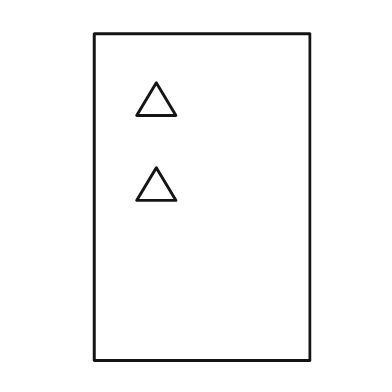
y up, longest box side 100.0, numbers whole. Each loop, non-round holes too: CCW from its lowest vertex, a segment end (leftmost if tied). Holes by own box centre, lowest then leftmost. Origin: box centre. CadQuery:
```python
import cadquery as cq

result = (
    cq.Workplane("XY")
    .moveTo(-33.0, -50.0)
    .lineTo(33.0, -50.0)
    .lineTo(33.0, 50.0)
    .lineTo(-33.0, 50.0)
    .close()
    .moveTo(-20.0, -1.0)
    .lineTo(-8.0, -1.0)
    .lineTo(-14.0, 9.0)
    .close()
    .moveTo(-20.0, 25.0)
    .lineTo(-8.0, 25.0)
    .lineTo(-14.0, 35.0)
    .close()
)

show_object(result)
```